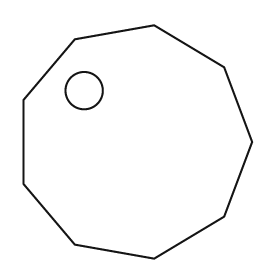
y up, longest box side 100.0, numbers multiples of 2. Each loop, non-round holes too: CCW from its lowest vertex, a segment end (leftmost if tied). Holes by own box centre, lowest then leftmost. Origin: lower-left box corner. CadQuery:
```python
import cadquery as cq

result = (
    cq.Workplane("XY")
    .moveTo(56.0, 0.0)
    .lineTo(86.0, 18.0)
    .lineTo(98.0, 50.0)
    .lineTo(86.0, 82.0)
    .lineTo(56.0, 100.0)
    .lineTo(22.0, 94.0)
    .lineTo(0.0, 68.0)
    .lineTo(0.0, 32.0)
    .lineTo(22.0, 6.0)
    .close()
    .moveTo(26.0, 72.0)
    .circle(8.0)
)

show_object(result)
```